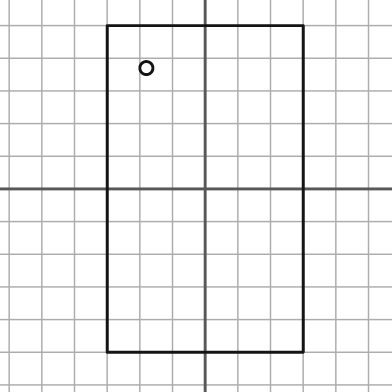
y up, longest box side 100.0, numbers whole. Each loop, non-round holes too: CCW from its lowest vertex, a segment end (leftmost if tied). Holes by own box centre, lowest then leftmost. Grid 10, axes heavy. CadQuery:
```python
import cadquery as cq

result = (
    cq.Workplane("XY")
    .moveTo(-30.0, -50.0)
    .lineTo(30.0, -50.0)
    .lineTo(30.0, 50.0)
    .lineTo(-30.0, 50.0)
    .close()
    .moveTo(-18.0, 37.0)
    .circle(2.0)
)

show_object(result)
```